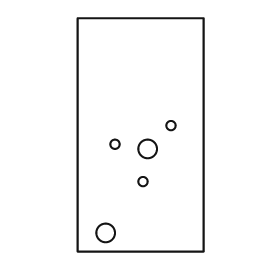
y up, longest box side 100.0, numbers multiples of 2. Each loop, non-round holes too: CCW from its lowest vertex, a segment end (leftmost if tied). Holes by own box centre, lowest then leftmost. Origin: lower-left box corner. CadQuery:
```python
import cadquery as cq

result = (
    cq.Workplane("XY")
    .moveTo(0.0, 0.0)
    .lineTo(54.0, 0.0)
    .lineTo(54.0, 100.0)
    .lineTo(0.0, 100.0)
    .close()
    .moveTo(12.0, 8.0)
    .circle(4.0)
    .moveTo(28.0, 30.0)
    .circle(2.0)
    .moveTo(30.0, 44.0)
    .circle(4.0)
    .moveTo(16.0, 46.0)
    .circle(2.0)
    .moveTo(40.0, 54.0)
    .circle(2.0)
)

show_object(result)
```